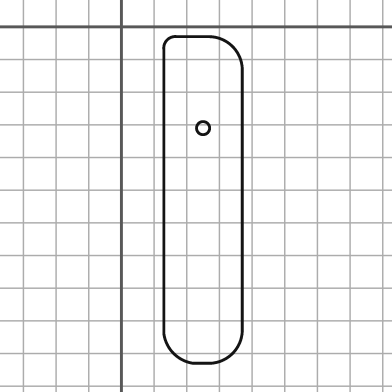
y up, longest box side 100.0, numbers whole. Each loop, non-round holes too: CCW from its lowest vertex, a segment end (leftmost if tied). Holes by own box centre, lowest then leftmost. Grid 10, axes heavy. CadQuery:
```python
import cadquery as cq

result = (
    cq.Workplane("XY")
    .moveTo(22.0, -103.0)
    .lineTo(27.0, -103.0)
    .threePointArc((34.0, -100.0), (37.0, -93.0))
    .lineTo(37.0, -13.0)
    .threePointArc((34.0, -6.0), (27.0, -3.0))
    .lineTo(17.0, -3.0)
    .threePointArc((14.0, -4.0), (13.0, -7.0))
    .lineTo(13.0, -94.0)
    .threePointArc((16.0, -100.0), (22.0, -103.0))
    .close()
    .moveTo(25.0, -31.0)
    .circle(2.0)
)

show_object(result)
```